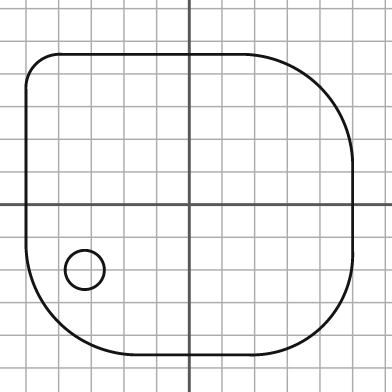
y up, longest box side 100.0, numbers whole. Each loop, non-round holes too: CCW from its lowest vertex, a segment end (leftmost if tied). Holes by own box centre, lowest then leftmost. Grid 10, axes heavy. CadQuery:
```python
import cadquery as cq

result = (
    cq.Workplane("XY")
    .moveTo(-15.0, -46.0)
    .lineTo(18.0, -46.0)
    .threePointArc((41.0, -37.0), (50.0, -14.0))
    .lineTo(50.0, 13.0)
    .threePointArc((40.0, 36.0), (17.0, 46.0))
    .lineTo(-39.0, 46.0)
    .threePointArc((-47.0, 43.0), (-50.0, 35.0))
    .lineTo(-50.0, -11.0)
    .threePointArc((-40.0, -36.0), (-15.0, -46.0))
    .close()
    .moveTo(-32.0, -20.0)
    .circle(6.0)
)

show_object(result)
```